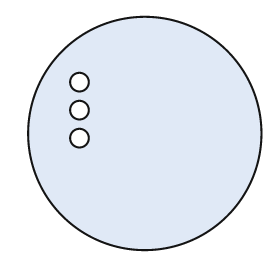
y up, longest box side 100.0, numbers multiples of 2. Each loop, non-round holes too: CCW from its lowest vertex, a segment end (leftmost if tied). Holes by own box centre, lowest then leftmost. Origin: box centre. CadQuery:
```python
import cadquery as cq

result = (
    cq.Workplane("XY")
    .moveTo(0.0, 0.0)
    .circle(50.0)
    .moveTo(-28.0, -2.0)
    .circle(4.0)
    .moveTo(-28.0, 10.0)
    .circle(4.0)
    .moveTo(-28.0, 22.0)
    .circle(4.0)
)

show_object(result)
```